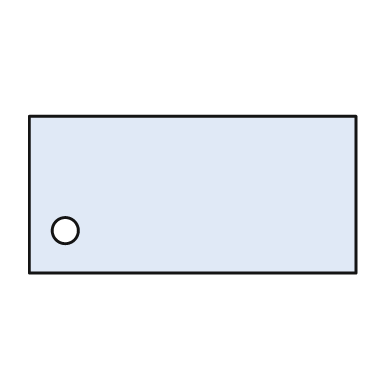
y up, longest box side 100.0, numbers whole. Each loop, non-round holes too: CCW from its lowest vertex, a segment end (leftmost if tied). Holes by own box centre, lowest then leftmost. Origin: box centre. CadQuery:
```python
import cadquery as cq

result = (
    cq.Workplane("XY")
    .moveTo(-50.0, -24.0)
    .lineTo(50.0, -24.0)
    .lineTo(50.0, 24.0)
    .lineTo(-50.0, 24.0)
    .close()
    .moveTo(-39.0, -11.0)
    .circle(4.0)
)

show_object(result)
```